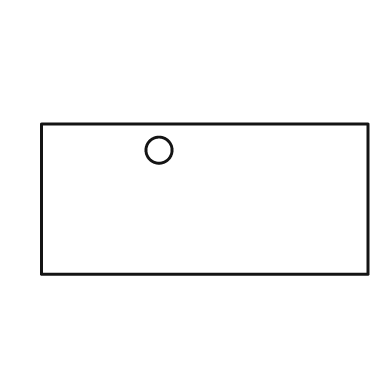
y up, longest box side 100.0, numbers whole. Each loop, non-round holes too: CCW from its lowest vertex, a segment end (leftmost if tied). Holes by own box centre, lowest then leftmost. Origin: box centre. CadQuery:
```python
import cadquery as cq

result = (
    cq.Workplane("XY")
    .moveTo(-50.0, -23.0)
    .lineTo(50.0, -23.0)
    .lineTo(50.0, 23.0)
    .lineTo(-50.0, 23.0)
    .close()
    .moveTo(-14.0, 15.0)
    .circle(4.0)
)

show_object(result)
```